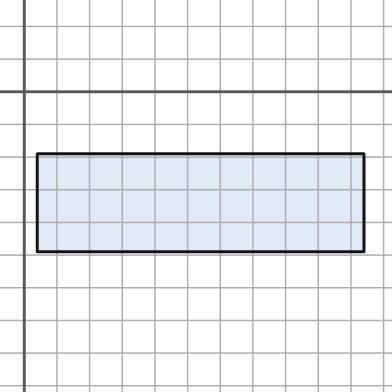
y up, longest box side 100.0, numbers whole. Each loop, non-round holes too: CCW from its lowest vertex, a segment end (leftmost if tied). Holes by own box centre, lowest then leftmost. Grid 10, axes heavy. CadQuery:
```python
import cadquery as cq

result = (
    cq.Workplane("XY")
    .moveTo(4.0, -49.0)
    .lineTo(104.0, -49.0)
    .lineTo(104.0, -19.0)
    .lineTo(4.0, -19.0)
    .close()
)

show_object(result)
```